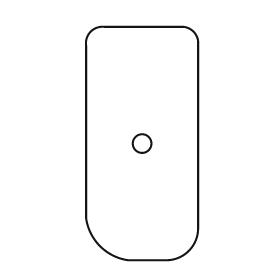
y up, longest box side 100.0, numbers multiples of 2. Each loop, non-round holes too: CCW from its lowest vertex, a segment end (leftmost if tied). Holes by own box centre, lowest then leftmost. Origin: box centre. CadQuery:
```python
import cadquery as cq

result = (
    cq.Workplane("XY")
    .moveTo(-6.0, -50.0)
    .lineTo(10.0, -50.0)
    .threePointArc((20.0, -46.0), (24.0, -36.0))
    .lineTo(24.0, 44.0)
    .threePointArc((22.0, 48.0), (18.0, 50.0))
    .lineTo(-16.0, 50.0)
    .threePointArc((-22.0, 48.0), (-24.0, 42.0))
    .lineTo(-24.0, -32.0)
    .threePointArc((-18.0, -44.0), (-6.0, -50.0))
    .close()
    .moveTo(0.0, 0.0)
    .circle(4.0)
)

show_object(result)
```